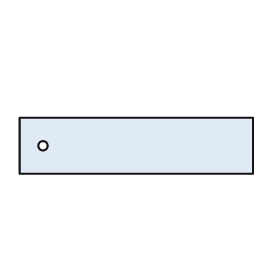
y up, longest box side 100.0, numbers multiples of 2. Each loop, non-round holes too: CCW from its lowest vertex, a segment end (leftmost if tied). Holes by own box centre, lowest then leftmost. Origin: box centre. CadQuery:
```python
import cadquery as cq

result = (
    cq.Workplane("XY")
    .moveTo(-50.0, -12.0)
    .lineTo(50.0, -12.0)
    .lineTo(50.0, 12.0)
    .lineTo(-50.0, 12.0)
    .close()
    .moveTo(-40.0, 0.0)
    .circle(2.0)
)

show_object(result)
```